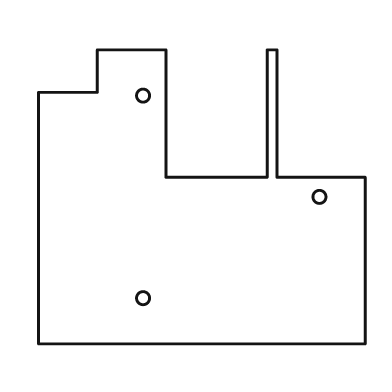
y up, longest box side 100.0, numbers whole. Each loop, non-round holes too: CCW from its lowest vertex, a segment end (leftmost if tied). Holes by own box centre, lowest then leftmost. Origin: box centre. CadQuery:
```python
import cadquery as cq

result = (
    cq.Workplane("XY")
    .moveTo(-50.0, -45.0)
    .lineTo(50.0, -45.0)
    .lineTo(50.0, 6.0)
    .lineTo(23.0, 6.0)
    .lineTo(23.0, 45.0)
    .lineTo(20.0, 45.0)
    .lineTo(20.0, 6.0)
    .lineTo(-11.0, 6.0)
    .lineTo(-11.0, 45.0)
    .lineTo(-32.0, 45.0)
    .lineTo(-32.0, 32.0)
    .lineTo(-50.0, 32.0)
    .close()
    .moveTo(-18.0, -31.0)
    .circle(2.0)
    .moveTo(36.0, 0.0)
    .circle(2.0)
    .moveTo(-18.0, 31.0)
    .circle(2.0)
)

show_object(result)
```